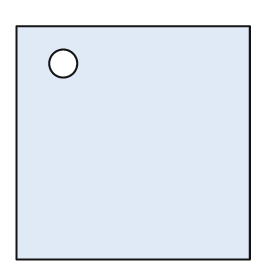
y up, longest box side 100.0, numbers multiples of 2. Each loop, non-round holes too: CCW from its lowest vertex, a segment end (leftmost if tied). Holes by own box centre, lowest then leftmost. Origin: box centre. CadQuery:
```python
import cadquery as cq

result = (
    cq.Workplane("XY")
    .moveTo(-50.0, -50.0)
    .lineTo(50.0, -50.0)
    .lineTo(50.0, 50.0)
    .lineTo(-50.0, 50.0)
    .close()
    .moveTo(-30.0, 34.0)
    .circle(6.0)
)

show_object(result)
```